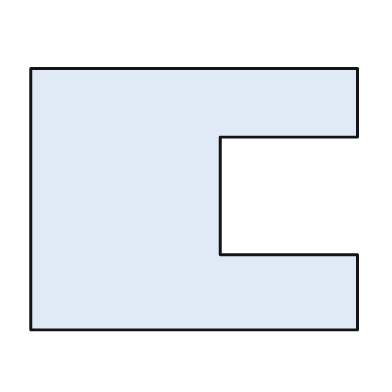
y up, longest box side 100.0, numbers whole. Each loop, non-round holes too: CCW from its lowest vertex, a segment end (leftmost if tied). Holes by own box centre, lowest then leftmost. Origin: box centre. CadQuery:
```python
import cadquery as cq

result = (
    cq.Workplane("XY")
    .moveTo(-50.0, -40.0)
    .lineTo(50.0, -40.0)
    .lineTo(50.0, -17.0)
    .lineTo(8.0, -17.0)
    .lineTo(8.0, 19.0)
    .lineTo(50.0, 19.0)
    .lineTo(50.0, 40.0)
    .lineTo(-50.0, 40.0)
    .close()
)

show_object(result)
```